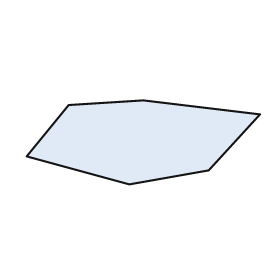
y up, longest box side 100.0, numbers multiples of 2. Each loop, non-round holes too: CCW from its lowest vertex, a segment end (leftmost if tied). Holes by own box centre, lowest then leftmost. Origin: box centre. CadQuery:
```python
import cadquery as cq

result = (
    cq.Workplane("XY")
    .moveTo(-6.0, -18.0)
    .lineTo(28.0, -12.0)
    .lineTo(50.0, 12.0)
    .lineTo(0.0, 18.0)
    .lineTo(-32.0, 16.0)
    .lineTo(-50.0, -6.0)
    .close()
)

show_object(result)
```